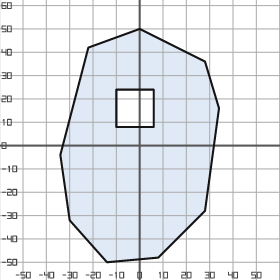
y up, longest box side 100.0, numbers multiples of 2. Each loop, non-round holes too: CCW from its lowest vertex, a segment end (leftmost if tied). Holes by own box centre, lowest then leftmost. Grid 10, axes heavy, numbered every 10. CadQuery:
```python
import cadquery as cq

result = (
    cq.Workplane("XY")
    .moveTo(-14.0, -50.0)
    .lineTo(8.0, -48.0)
    .lineTo(28.0, -28.0)
    .lineTo(34.0, 16.0)
    .lineTo(28.0, 36.0)
    .lineTo(0.0, 50.0)
    .lineTo(-22.0, 42.0)
    .lineTo(-34.0, -4.0)
    .lineTo(-30.0, -32.0)
    .close()
    .moveTo(-10.0, 8.0)
    .lineTo(6.0, 8.0)
    .lineTo(6.0, 24.0)
    .lineTo(-10.0, 24.0)
    .close()
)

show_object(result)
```